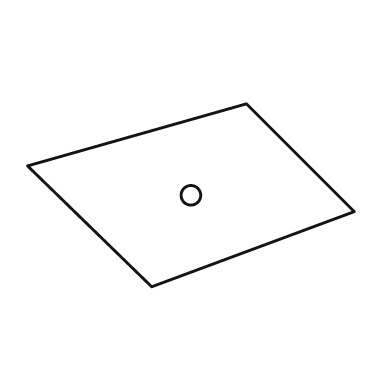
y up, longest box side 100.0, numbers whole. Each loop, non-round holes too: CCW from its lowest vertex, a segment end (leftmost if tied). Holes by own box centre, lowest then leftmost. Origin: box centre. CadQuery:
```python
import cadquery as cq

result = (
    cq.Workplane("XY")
    .moveTo(-12.0, -28.0)
    .lineTo(50.0, -5.0)
    .lineTo(17.0, 28.0)
    .lineTo(-50.0, 9.0)
    .close()
    .moveTo(0.0, 0.0)
    .circle(3.0)
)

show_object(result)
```